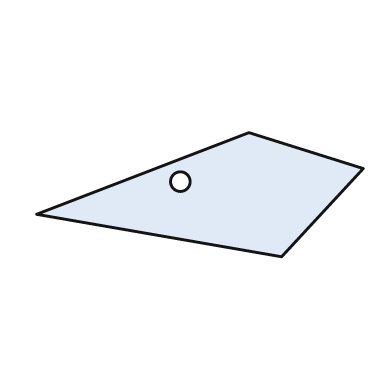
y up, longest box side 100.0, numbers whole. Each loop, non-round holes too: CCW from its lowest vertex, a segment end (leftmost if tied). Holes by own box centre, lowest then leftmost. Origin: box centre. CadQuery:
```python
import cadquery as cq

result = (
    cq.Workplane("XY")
    .moveTo(25.0, -19.0)
    .lineTo(50.0, 8.0)
    .lineTo(15.0, 19.0)
    .lineTo(-50.0, -6.0)
    .close()
    .moveTo(-6.0, 4.0)
    .circle(3.0)
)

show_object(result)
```